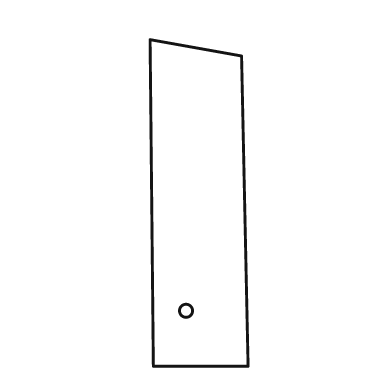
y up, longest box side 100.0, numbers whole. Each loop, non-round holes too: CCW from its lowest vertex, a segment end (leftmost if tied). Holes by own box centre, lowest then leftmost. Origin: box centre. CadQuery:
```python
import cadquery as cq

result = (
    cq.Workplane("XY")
    .moveTo(-14.0, -50.0)
    .lineTo(15.0, -50.0)
    .lineTo(13.0, 45.0)
    .lineTo(-15.0, 50.0)
    .close()
    .moveTo(-4.0, -33.0)
    .circle(2.0)
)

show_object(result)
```